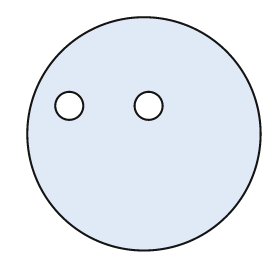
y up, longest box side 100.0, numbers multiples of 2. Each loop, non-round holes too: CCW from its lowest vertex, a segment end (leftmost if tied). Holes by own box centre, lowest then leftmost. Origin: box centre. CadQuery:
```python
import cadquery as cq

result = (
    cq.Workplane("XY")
    .moveTo(0.0, 0.0)
    .circle(50.0)
    .moveTo(-32.0, 12.0)
    .circle(6.0)
    .moveTo(2.0, 12.0)
    .circle(6.0)
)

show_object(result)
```